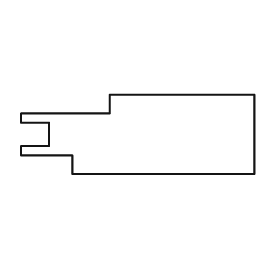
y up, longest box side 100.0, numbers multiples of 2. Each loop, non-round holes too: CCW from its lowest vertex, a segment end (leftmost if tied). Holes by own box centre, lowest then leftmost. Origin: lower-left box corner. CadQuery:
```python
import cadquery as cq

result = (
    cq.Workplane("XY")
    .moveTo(22.0, 0.0)
    .lineTo(100.0, 0.0)
    .lineTo(100.0, 34.0)
    .lineTo(38.0, 34.0)
    .lineTo(38.0, 26.0)
    .lineTo(0.0, 26.0)
    .lineTo(0.0, 22.0)
    .lineTo(12.0, 22.0)
    .lineTo(12.0, 12.0)
    .lineTo(0.0, 12.0)
    .lineTo(0.0, 8.0)
    .lineTo(22.0, 8.0)
    .close()
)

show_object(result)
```